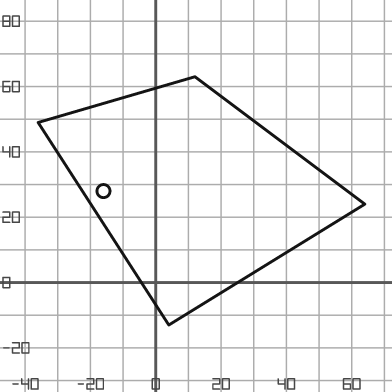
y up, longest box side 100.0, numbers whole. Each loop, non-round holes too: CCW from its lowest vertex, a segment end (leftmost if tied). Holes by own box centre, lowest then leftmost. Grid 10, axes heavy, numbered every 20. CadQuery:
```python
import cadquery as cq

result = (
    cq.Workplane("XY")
    .moveTo(4.0, -13.0)
    .lineTo(64.0, 24.0)
    .lineTo(12.0, 63.0)
    .lineTo(-36.0, 49.0)
    .close()
    .moveTo(-16.0, 28.0)
    .circle(2.0)
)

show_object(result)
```